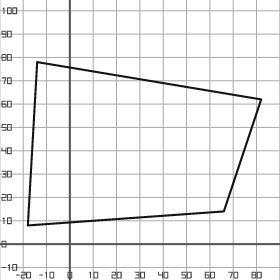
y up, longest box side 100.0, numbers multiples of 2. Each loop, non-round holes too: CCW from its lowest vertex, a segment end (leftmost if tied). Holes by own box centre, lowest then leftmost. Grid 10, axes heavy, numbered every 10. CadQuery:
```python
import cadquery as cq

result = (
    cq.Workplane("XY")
    .moveTo(-18.0, 8.0)
    .lineTo(66.0, 14.0)
    .lineTo(82.0, 62.0)
    .lineTo(-14.0, 78.0)
    .close()
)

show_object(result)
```